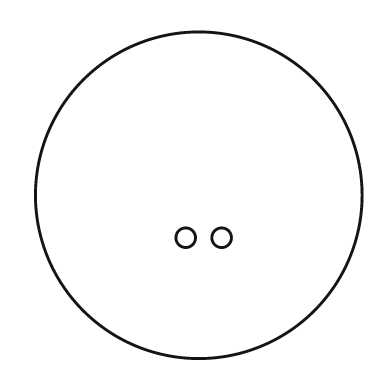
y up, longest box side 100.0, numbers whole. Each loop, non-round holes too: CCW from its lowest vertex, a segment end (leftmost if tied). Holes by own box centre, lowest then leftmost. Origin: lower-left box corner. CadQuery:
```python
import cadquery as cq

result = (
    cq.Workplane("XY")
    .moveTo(50.0, 50.0)
    .circle(50.0)
    .moveTo(46.0, 37.0)
    .circle(3.0)
    .moveTo(57.0, 37.0)
    .circle(3.0)
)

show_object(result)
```